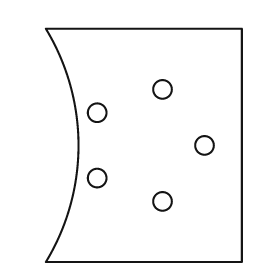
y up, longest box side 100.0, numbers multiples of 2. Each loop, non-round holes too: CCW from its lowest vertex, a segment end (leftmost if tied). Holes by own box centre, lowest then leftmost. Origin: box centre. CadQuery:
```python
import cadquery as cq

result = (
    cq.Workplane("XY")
    .moveTo(-42.0, -50.0)
    .lineTo(42.0, -50.0)
    .lineTo(42.0, 50.0)
    .lineTo(-42.0, 50.0)
    .threePointArc((-28.0, 0.0), (-42.0, -50.0))
    .close()
    .moveTo(8.0, -24.0)
    .circle(4.0)
    .moveTo(-20.0, -14.0)
    .circle(4.0)
    .moveTo(26.0, 0.0)
    .circle(4.0)
    .moveTo(-20.0, 14.0)
    .circle(4.0)
    .moveTo(8.0, 24.0)
    .circle(4.0)
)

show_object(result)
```